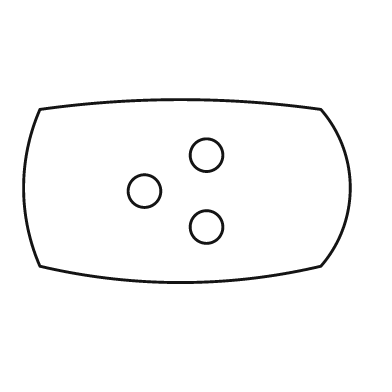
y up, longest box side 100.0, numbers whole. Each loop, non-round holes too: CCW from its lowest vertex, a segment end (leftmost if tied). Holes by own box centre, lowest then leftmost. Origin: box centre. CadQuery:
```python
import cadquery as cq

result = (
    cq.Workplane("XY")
    .moveTo(-45.0, -23.0)
    .threePointArc((-2.0, -28.0), (41.0, -23.0))
    .threePointArc((50.0, 1.0), (41.0, 25.0))
    .threePointArc((-2.0, 28.0), (-45.0, 25.0))
    .threePointArc((-50.0, 1.0), (-45.0, -23.0))
    .close()
    .moveTo(6.0, -11.0)
    .circle(5.0)
    .moveTo(-13.0, 0.0)
    .circle(5.0)
    .moveTo(6.0, 11.0)
    .circle(5.0)
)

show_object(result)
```